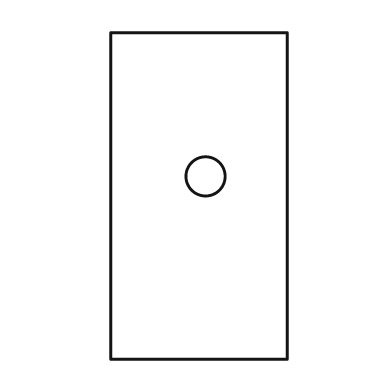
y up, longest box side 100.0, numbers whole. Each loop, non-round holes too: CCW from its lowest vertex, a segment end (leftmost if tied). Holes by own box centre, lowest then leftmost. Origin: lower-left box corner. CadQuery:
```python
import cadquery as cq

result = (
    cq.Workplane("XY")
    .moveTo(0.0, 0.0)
    .lineTo(54.0, 0.0)
    .lineTo(54.0, 100.0)
    .lineTo(0.0, 100.0)
    .close()
    .moveTo(29.0, 56.0)
    .circle(6.0)
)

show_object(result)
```